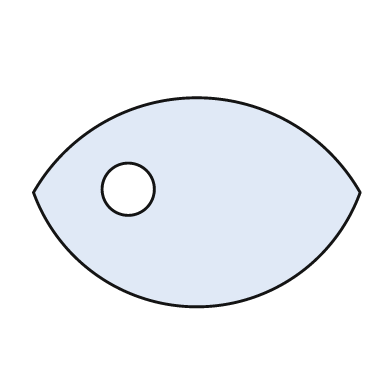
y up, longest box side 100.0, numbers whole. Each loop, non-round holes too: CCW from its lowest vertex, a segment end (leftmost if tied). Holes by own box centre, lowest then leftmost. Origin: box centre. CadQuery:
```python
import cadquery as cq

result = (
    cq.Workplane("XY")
    .moveTo(-50.0, 3.0)
    .threePointArc((0.0, -32.0), (50.0, 3.0))
    .threePointArc((0.0, 32.0), (-50.0, 3.0))
    .close()
    .moveTo(-21.0, 4.0)
    .circle(8.0)
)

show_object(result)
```